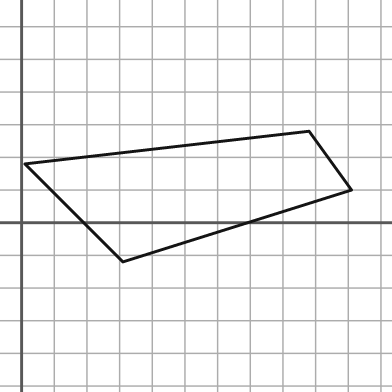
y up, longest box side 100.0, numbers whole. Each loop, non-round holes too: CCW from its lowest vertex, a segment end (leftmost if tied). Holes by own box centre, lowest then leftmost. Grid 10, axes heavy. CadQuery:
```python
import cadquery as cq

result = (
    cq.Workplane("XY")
    .moveTo(31.0, -12.0)
    .lineTo(101.0, 10.0)
    .lineTo(88.0, 28.0)
    .lineTo(1.0, 18.0)
    .close()
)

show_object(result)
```